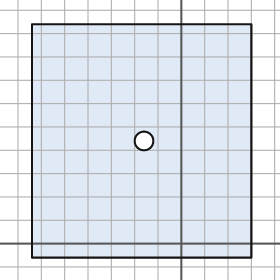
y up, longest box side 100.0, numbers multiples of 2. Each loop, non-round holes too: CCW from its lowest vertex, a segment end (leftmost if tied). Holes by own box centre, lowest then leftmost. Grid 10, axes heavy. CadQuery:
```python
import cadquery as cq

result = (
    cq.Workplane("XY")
    .moveTo(-64.0, -6.0)
    .lineTo(30.0, -6.0)
    .lineTo(30.0, 94.0)
    .lineTo(-64.0, 94.0)
    .close()
    .moveTo(-16.0, 44.0)
    .circle(4.0)
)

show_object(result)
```